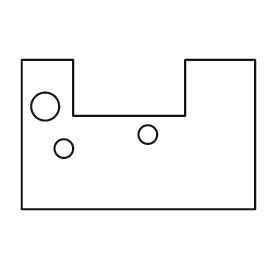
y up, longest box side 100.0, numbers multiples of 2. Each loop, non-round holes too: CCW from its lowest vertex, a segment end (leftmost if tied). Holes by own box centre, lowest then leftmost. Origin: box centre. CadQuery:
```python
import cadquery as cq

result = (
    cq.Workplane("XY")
    .moveTo(-50.0, -32.0)
    .lineTo(50.0, -32.0)
    .lineTo(50.0, 32.0)
    .lineTo(20.0, 32.0)
    .lineTo(20.0, 8.0)
    .lineTo(-28.0, 8.0)
    .lineTo(-28.0, 32.0)
    .lineTo(-50.0, 32.0)
    .close()
    .moveTo(-32.0, -6.0)
    .circle(4.0)
    .moveTo(4.0, 0.0)
    .circle(4.0)
    .moveTo(-40.0, 12.0)
    .circle(6.0)
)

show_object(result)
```